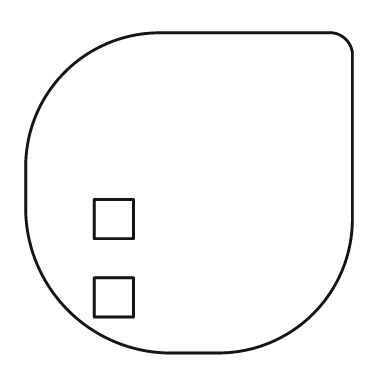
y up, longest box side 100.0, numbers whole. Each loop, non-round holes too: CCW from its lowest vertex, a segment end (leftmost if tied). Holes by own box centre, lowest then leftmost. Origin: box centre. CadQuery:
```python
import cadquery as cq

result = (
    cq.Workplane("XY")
    .moveTo(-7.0, -49.0)
    .lineTo(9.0, -49.0)
    .threePointArc((38.0, -37.0), (50.0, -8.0))
    .lineTo(50.0, 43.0)
    .threePointArc((48.0, 47.0), (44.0, 49.0))
    .lineTo(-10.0, 49.0)
    .threePointArc((-38.0, 37.0), (-50.0, 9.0))
    .lineTo(-50.0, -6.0)
    .threePointArc((-37.0, -36.0), (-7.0, -49.0))
    .close()
    .moveTo(-29.0, -38.0)
    .lineTo(-17.0, -38.0)
    .lineTo(-17.0, -26.0)
    .lineTo(-29.0, -26.0)
    .close()
    .moveTo(-29.0, -14.0)
    .lineTo(-17.0, -14.0)
    .lineTo(-17.0, -2.0)
    .lineTo(-29.0, -2.0)
    .close()
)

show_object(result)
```